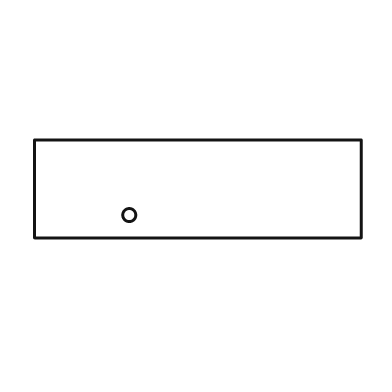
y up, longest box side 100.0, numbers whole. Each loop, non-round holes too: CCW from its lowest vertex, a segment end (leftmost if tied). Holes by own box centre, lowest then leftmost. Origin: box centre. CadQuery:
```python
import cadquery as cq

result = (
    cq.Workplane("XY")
    .moveTo(-50.0, -15.0)
    .lineTo(50.0, -15.0)
    .lineTo(50.0, 15.0)
    .lineTo(-50.0, 15.0)
    .close()
    .moveTo(-21.0, -8.0)
    .circle(2.0)
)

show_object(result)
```